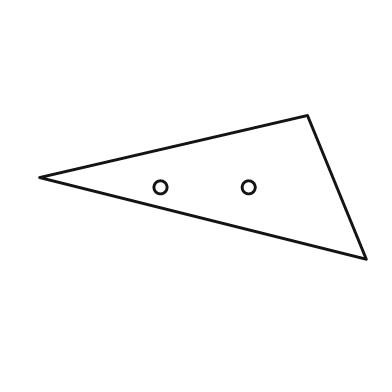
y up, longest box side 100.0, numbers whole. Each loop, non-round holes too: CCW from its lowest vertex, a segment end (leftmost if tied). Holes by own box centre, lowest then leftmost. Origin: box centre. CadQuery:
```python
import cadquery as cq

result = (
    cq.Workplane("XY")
    .moveTo(50.0, -22.0)
    .lineTo(32.0, 22.0)
    .lineTo(-50.0, 3.0)
    .close()
    .moveTo(-13.0, 0.0)
    .circle(2.0)
    .moveTo(14.0, 0.0)
    .circle(2.0)
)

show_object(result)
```